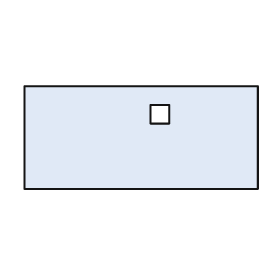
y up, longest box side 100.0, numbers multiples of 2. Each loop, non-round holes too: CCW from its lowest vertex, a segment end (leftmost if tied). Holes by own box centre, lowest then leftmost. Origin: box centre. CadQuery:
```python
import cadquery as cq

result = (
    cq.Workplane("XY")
    .moveTo(-50.0, -22.0)
    .lineTo(50.0, -22.0)
    .lineTo(50.0, 22.0)
    .lineTo(-50.0, 22.0)
    .close()
    .moveTo(4.0, 6.0)
    .lineTo(12.0, 6.0)
    .lineTo(12.0, 14.0)
    .lineTo(4.0, 14.0)
    .close()
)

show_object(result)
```